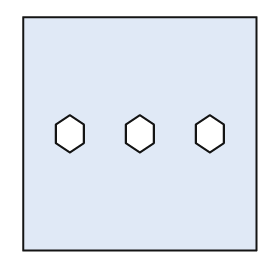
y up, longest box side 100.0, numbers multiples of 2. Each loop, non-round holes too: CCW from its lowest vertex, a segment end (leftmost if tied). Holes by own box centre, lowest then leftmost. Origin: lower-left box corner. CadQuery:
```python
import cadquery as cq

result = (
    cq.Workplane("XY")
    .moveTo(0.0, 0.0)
    .lineTo(100.0, 0.0)
    .lineTo(100.0, 100.0)
    .lineTo(0.0, 100.0)
    .close()
    .moveTo(20.0, 42.0)
    .lineTo(26.0, 46.0)
    .lineTo(26.0, 54.0)
    .lineTo(20.0, 58.0)
    .lineTo(14.0, 54.0)
    .lineTo(14.0, 46.0)
    .close()
    .moveTo(50.0, 42.0)
    .lineTo(56.0, 46.0)
    .lineTo(56.0, 54.0)
    .lineTo(50.0, 58.0)
    .lineTo(44.0, 54.0)
    .lineTo(44.0, 46.0)
    .close()
    .moveTo(80.0, 42.0)
    .lineTo(86.0, 46.0)
    .lineTo(86.0, 54.0)
    .lineTo(80.0, 58.0)
    .lineTo(74.0, 54.0)
    .lineTo(74.0, 46.0)
    .close()
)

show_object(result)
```